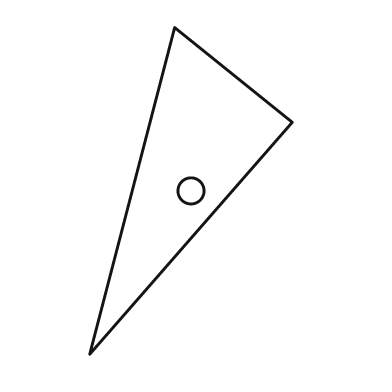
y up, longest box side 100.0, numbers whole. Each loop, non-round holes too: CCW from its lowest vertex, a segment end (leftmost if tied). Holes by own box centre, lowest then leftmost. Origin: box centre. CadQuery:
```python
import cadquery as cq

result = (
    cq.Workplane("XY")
    .moveTo(-31.0, -50.0)
    .lineTo(31.0, 21.0)
    .lineTo(-5.0, 50.0)
    .close()
    .moveTo(0.0, 0.0)
    .circle(4.0)
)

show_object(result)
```